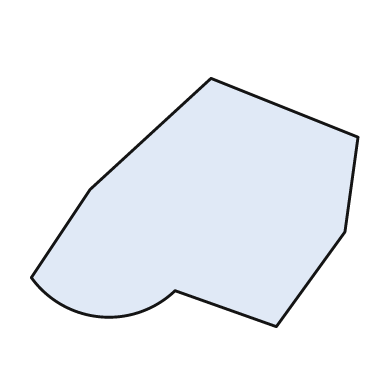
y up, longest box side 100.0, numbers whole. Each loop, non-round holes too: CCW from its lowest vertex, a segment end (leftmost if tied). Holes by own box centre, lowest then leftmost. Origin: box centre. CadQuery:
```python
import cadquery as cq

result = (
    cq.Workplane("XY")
    .moveTo(25.0, -38.0)
    .lineTo(46.0, -9.0)
    .lineTo(50.0, 20.0)
    .lineTo(5.0, 38.0)
    .lineTo(-32.0, 4.0)
    .lineTo(-50.0, -23.0)
    .threePointArc((-29.0, -35.0), (-6.0, -27.0))
    .close()
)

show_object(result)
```